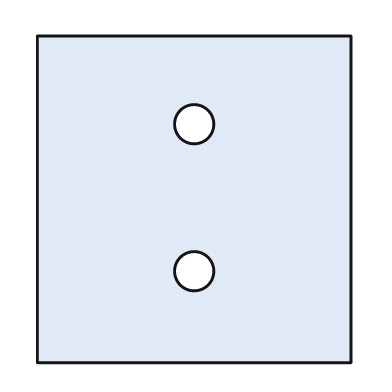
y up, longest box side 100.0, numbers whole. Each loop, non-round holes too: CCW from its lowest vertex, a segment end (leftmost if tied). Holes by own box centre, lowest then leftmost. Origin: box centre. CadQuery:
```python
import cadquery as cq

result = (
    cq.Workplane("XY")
    .moveTo(-48.0, -50.0)
    .lineTo(48.0, -50.0)
    .lineTo(48.0, 50.0)
    .lineTo(-48.0, 50.0)
    .close()
    .moveTo(0.0, -22.0)
    .circle(6.0)
    .moveTo(0.0, 23.0)
    .circle(6.0)
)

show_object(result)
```